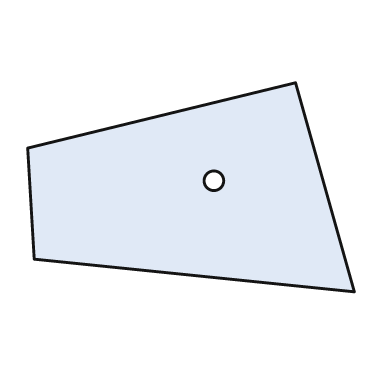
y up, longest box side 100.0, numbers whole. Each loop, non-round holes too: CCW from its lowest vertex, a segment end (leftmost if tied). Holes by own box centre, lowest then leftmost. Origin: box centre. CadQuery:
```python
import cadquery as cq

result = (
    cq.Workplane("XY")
    .moveTo(50.0, -32.0)
    .lineTo(32.0, 32.0)
    .lineTo(-50.0, 12.0)
    .lineTo(-48.0, -22.0)
    .close()
    .moveTo(7.0, 2.0)
    .circle(3.0)
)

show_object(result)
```